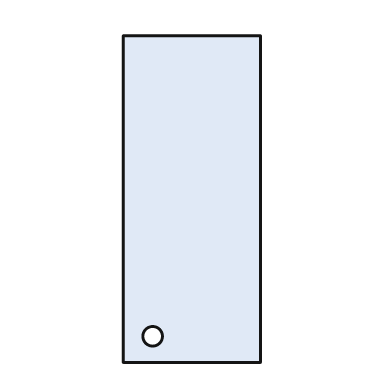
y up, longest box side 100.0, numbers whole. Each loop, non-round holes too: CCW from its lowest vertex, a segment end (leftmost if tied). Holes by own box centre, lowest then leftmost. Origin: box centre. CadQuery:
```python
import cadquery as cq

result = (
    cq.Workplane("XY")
    .moveTo(-21.0, -50.0)
    .lineTo(21.0, -50.0)
    .lineTo(21.0, 50.0)
    .lineTo(-21.0, 50.0)
    .close()
    .moveTo(-12.0, -42.0)
    .circle(3.0)
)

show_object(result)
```